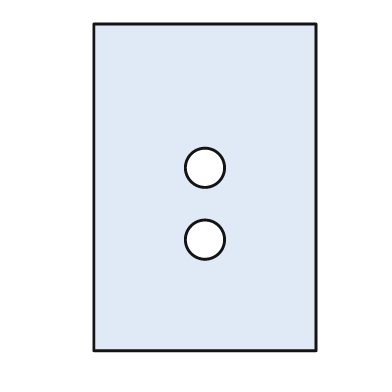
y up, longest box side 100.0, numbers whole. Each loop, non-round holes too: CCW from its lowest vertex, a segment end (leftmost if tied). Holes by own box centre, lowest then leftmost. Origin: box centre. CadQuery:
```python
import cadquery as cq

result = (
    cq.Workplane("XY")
    .moveTo(-34.0, -50.0)
    .lineTo(34.0, -50.0)
    .lineTo(34.0, 50.0)
    .lineTo(-34.0, 50.0)
    .close()
    .moveTo(0.0, -16.0)
    .circle(6.0)
    .moveTo(0.0, 6.0)
    .circle(6.0)
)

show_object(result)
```